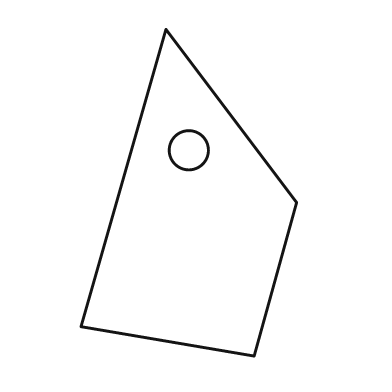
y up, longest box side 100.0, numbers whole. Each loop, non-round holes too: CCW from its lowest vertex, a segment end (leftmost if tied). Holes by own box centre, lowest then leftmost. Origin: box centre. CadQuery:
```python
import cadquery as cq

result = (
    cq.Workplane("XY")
    .moveTo(20.0, -50.0)
    .lineTo(33.0, -3.0)
    .lineTo(-7.0, 50.0)
    .lineTo(-33.0, -41.0)
    .close()
    .moveTo(0.0, 13.0)
    .circle(6.0)
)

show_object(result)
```